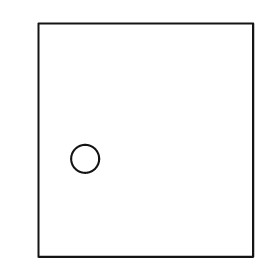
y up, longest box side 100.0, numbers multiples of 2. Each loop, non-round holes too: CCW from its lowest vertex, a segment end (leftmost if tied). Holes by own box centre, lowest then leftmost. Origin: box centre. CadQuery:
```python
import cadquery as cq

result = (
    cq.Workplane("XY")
    .moveTo(-46.0, -50.0)
    .lineTo(46.0, -50.0)
    .lineTo(46.0, 50.0)
    .lineTo(-46.0, 50.0)
    .close()
    .moveTo(-26.0, -8.0)
    .circle(6.0)
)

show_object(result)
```